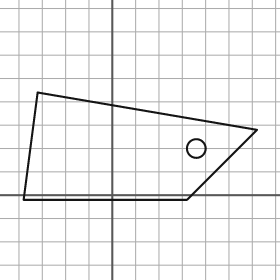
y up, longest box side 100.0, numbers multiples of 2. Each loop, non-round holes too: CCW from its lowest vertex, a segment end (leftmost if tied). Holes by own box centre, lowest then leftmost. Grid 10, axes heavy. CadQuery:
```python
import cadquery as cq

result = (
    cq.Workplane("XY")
    .moveTo(-38.0, -2.0)
    .lineTo(32.0, -2.0)
    .lineTo(62.0, 28.0)
    .lineTo(-32.0, 44.0)
    .close()
    .moveTo(36.0, 20.0)
    .circle(4.0)
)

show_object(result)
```